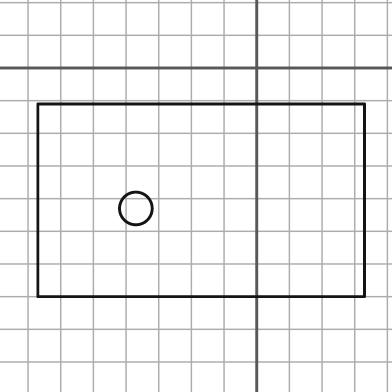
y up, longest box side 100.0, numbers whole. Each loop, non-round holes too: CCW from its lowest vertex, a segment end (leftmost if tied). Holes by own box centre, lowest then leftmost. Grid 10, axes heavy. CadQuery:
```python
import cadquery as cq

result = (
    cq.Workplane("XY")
    .moveTo(-67.0, -70.0)
    .lineTo(33.0, -70.0)
    .lineTo(33.0, -11.0)
    .lineTo(-67.0, -11.0)
    .close()
    .moveTo(-37.0, -43.0)
    .circle(5.0)
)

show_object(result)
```